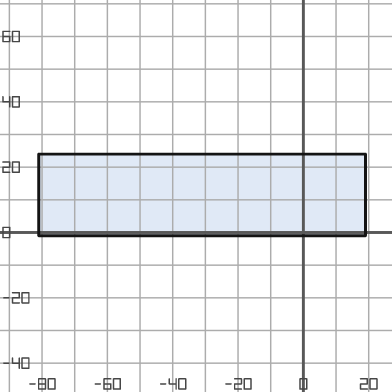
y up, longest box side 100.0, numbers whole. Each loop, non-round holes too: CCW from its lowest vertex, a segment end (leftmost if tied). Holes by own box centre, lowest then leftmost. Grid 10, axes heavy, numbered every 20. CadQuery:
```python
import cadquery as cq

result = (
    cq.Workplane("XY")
    .moveTo(-81.0, -1.0)
    .lineTo(19.0, -1.0)
    .lineTo(19.0, 24.0)
    .lineTo(-81.0, 24.0)
    .close()
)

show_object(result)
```